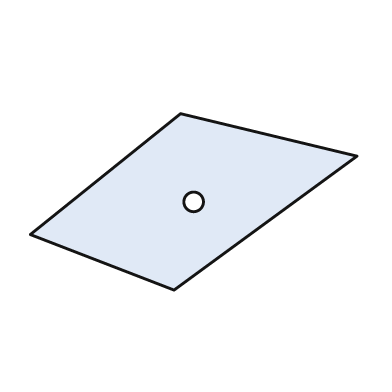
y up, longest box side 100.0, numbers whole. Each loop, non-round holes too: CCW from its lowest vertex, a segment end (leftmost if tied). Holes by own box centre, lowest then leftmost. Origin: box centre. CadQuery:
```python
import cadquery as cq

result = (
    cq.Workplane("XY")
    .moveTo(-6.0, -27.0)
    .lineTo(50.0, 14.0)
    .lineTo(-4.0, 27.0)
    .lineTo(-50.0, -10.0)
    .close()
    .moveTo(0.0, 0.0)
    .circle(3.0)
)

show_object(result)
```